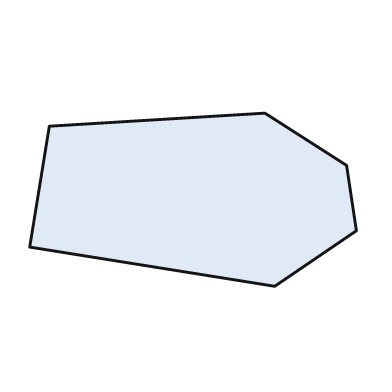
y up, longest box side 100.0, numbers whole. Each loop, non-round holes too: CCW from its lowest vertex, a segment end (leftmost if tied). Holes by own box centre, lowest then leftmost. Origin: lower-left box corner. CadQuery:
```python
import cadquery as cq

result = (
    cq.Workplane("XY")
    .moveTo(75.0, 0.0)
    .lineTo(100.0, 17.0)
    .lineTo(97.0, 37.0)
    .lineTo(72.0, 53.0)
    .lineTo(6.0, 49.0)
    .lineTo(0.0, 12.0)
    .close()
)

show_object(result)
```